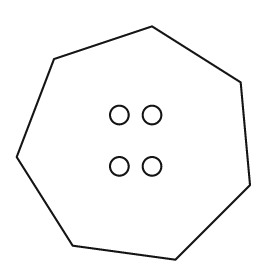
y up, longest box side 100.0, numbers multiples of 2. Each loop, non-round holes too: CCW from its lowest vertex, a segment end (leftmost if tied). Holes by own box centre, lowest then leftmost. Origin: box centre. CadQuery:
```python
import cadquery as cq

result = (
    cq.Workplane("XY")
    .moveTo(18.0, -50.0)
    .lineTo(50.0, -18.0)
    .lineTo(46.0, 26.0)
    .lineTo(8.0, 50.0)
    .lineTo(-34.0, 36.0)
    .lineTo(-50.0, -6.0)
    .lineTo(-26.0, -44.0)
    .close()
    .moveTo(-6.0, -10.0)
    .circle(4.0)
    .moveTo(8.0, -10.0)
    .circle(4.0)
    .moveTo(-6.0, 12.0)
    .circle(4.0)
    .moveTo(8.0, 12.0)
    .circle(4.0)
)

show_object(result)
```